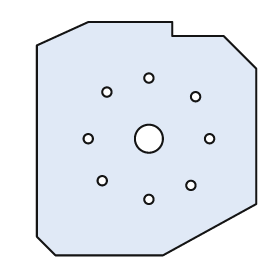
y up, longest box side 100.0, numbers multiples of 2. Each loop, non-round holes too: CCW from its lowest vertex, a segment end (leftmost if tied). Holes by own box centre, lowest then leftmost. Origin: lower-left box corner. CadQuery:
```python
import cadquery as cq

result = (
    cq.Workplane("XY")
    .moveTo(8.0, 0.0)
    .lineTo(54.0, 0.0)
    .lineTo(94.0, 22.0)
    .lineTo(94.0, 80.0)
    .lineTo(80.0, 94.0)
    .lineTo(58.0, 94.0)
    .lineTo(58.0, 100.0)
    .lineTo(22.0, 100.0)
    .lineTo(0.0, 90.0)
    .lineTo(0.0, 8.0)
    .close()
    .moveTo(48.0, 24.0)
    .circle(2.0)
    .moveTo(66.0, 30.0)
    .circle(2.0)
    .moveTo(28.0, 32.0)
    .circle(2.0)
    .moveTo(22.0, 50.0)
    .circle(2.0)
    .moveTo(48.0, 50.0)
    .circle(6.0)
    .moveTo(74.0, 50.0)
    .circle(2.0)
    .moveTo(68.0, 68.0)
    .circle(2.0)
    .moveTo(30.0, 70.0)
    .circle(2.0)
    .moveTo(48.0, 76.0)
    .circle(2.0)
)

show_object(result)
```